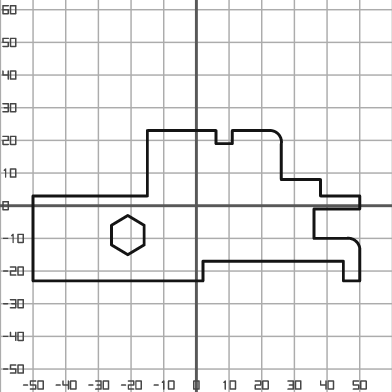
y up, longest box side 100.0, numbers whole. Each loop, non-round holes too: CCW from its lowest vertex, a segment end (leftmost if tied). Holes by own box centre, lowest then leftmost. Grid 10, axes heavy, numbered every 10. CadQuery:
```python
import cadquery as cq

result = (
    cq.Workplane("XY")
    .moveTo(-50.0, -23.0)
    .lineTo(2.0, -23.0)
    .lineTo(2.0, -17.0)
    .lineTo(45.0, -17.0)
    .lineTo(45.0, -23.0)
    .lineTo(50.0, -23.0)
    .lineTo(50.0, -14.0)
    .threePointArc((49.0, -11.0), (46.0, -10.0))
    .lineTo(36.0, -10.0)
    .lineTo(36.0, -1.0)
    .lineTo(50.0, -1.0)
    .lineTo(50.0, 3.0)
    .lineTo(38.0, 3.0)
    .lineTo(38.0, 8.0)
    .lineTo(26.0, 8.0)
    .lineTo(26.0, 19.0)
    .threePointArc((25.0, 22.0), (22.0, 23.0))
    .lineTo(11.0, 23.0)
    .lineTo(11.0, 19.0)
    .lineTo(6.0, 19.0)
    .lineTo(6.0, 23.0)
    .lineTo(-15.0, 23.0)
    .lineTo(-15.0, 3.0)
    .lineTo(-50.0, 3.0)
    .close()
    .moveTo(-21.0, -15.0)
    .lineTo(-16.0, -12.0)
    .lineTo(-16.0, -6.0)
    .lineTo(-21.0, -3.0)
    .lineTo(-26.0, -6.0)
    .lineTo(-26.0, -12.0)
    .close()
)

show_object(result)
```